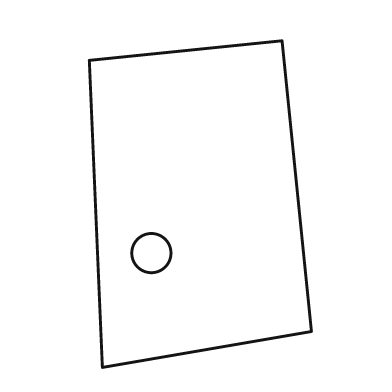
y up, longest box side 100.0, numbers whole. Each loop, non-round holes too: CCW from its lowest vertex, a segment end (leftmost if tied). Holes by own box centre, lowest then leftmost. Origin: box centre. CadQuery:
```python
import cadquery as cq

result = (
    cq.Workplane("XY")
    .moveTo(-30.0, -50.0)
    .lineTo(34.0, -39.0)
    .lineTo(25.0, 50.0)
    .lineTo(-34.0, 44.0)
    .close()
    .moveTo(-15.0, -15.0)
    .circle(6.0)
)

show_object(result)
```